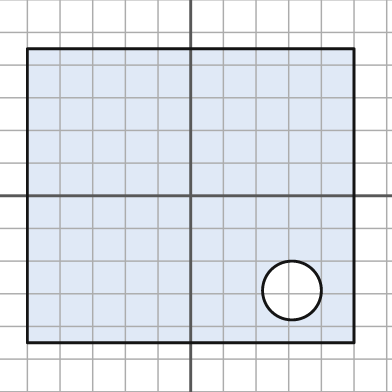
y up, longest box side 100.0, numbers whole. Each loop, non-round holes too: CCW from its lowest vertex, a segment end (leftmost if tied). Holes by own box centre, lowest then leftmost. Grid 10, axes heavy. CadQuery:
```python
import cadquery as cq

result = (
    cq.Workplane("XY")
    .moveTo(-50.0, -45.0)
    .lineTo(50.0, -45.0)
    .lineTo(50.0, 45.0)
    .lineTo(-50.0, 45.0)
    .close()
    .moveTo(31.0, -29.0)
    .circle(9.0)
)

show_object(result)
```